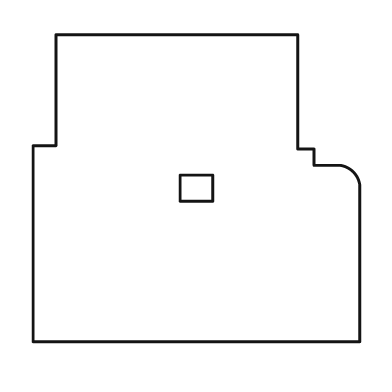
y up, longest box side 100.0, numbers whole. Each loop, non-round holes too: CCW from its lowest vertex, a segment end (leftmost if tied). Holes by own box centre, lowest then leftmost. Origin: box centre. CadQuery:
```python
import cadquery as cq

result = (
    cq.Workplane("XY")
    .moveTo(-50.0, -47.0)
    .lineTo(50.0, -47.0)
    .lineTo(50.0, 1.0)
    .threePointArc((48.0, 5.0), (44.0, 7.0))
    .lineTo(36.0, 7.0)
    .lineTo(36.0, 12.0)
    .lineTo(31.0, 12.0)
    .lineTo(31.0, 47.0)
    .lineTo(-43.0, 47.0)
    .lineTo(-43.0, 13.0)
    .lineTo(-50.0, 13.0)
    .close()
    .moveTo(-5.0, -4.0)
    .lineTo(5.0, -4.0)
    .lineTo(5.0, 4.0)
    .lineTo(-5.0, 4.0)
    .close()
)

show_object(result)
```